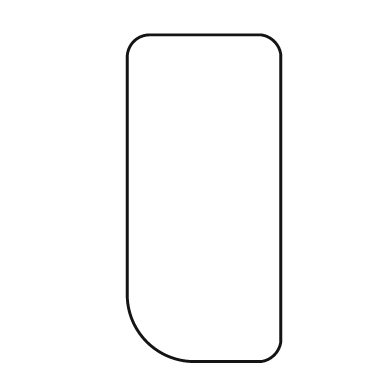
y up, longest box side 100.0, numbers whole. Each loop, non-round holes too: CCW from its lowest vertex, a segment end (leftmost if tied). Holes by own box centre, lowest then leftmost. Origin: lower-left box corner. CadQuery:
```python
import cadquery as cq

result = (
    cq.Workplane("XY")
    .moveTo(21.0, 0.0)
    .lineTo(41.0, 0.0)
    .threePointArc((45.0, 2.0), (47.0, 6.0))
    .lineTo(47.0, 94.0)
    .threePointArc((45.0, 98.0), (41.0, 100.0))
    .lineTo(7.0, 100.0)
    .threePointArc((2.0, 98.0), (0.0, 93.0))
    .lineTo(0.0, 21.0)
    .threePointArc((6.0, 6.0), (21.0, 0.0))
    .close()
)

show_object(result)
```